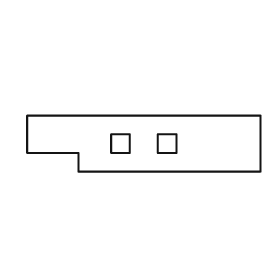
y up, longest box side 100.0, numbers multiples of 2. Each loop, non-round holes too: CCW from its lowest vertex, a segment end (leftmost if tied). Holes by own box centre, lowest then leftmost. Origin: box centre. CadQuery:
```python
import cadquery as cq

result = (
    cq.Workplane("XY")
    .moveTo(-28.0, -12.0)
    .lineTo(50.0, -12.0)
    .lineTo(50.0, 12.0)
    .lineTo(-50.0, 12.0)
    .lineTo(-50.0, -4.0)
    .lineTo(-28.0, -4.0)
    .close()
    .moveTo(-14.0, -4.0)
    .lineTo(-6.0, -4.0)
    .lineTo(-6.0, 4.0)
    .lineTo(-14.0, 4.0)
    .close()
    .moveTo(6.0, -4.0)
    .lineTo(14.0, -4.0)
    .lineTo(14.0, 4.0)
    .lineTo(6.0, 4.0)
    .close()
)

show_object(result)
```